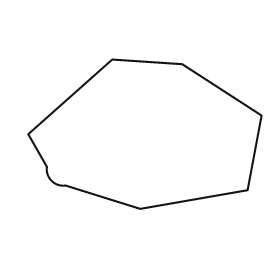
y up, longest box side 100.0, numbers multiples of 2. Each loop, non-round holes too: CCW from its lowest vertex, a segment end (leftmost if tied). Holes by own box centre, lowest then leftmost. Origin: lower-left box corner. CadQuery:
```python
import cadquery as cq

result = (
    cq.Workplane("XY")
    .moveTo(48.0, 0.0)
    .lineTo(94.0, 8.0)
    .lineTo(100.0, 40.0)
    .lineTo(66.0, 62.0)
    .lineTo(36.0, 64.0)
    .lineTo(0.0, 32.0)
    .lineTo(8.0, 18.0)
    .threePointArc((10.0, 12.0), (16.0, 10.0))
    .close()
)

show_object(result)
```